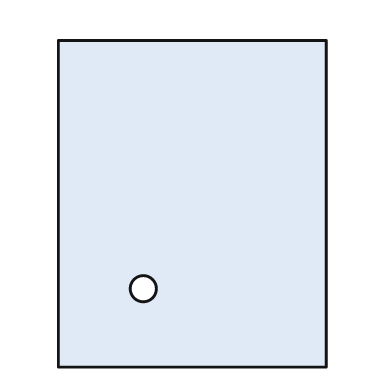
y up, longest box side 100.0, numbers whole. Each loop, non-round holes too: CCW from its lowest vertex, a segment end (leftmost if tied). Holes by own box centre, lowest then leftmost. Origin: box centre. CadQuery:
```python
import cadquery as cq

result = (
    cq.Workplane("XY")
    .moveTo(-41.0, -50.0)
    .lineTo(41.0, -50.0)
    .lineTo(41.0, 50.0)
    .lineTo(-41.0, 50.0)
    .close()
    .moveTo(-15.0, -26.0)
    .circle(4.0)
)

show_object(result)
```